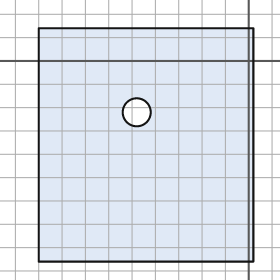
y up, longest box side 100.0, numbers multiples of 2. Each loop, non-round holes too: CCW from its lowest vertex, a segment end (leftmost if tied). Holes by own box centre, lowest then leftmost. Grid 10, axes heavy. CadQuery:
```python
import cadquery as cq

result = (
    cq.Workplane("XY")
    .moveTo(-90.0, -86.0)
    .lineTo(2.0, -86.0)
    .lineTo(2.0, 14.0)
    .lineTo(-90.0, 14.0)
    .close()
    .moveTo(-48.0, -22.0)
    .circle(6.0)
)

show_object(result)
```